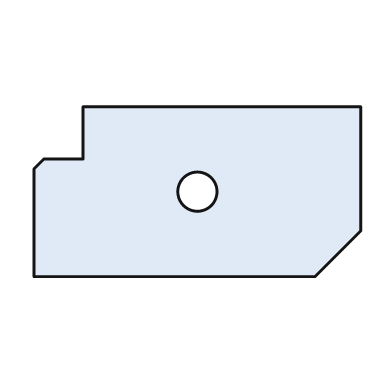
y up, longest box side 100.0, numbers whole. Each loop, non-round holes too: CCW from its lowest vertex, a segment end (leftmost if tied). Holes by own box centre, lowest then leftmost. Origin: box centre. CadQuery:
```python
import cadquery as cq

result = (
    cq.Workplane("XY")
    .moveTo(-50.0, -26.0)
    .lineTo(36.0, -26.0)
    .lineTo(50.0, -12.0)
    .lineTo(50.0, 26.0)
    .lineTo(-35.0, 26.0)
    .lineTo(-35.0, 10.0)
    .lineTo(-47.0, 10.0)
    .lineTo(-50.0, 7.0)
    .close()
    .moveTo(0.0, 0.0)
    .circle(6.0)
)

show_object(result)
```